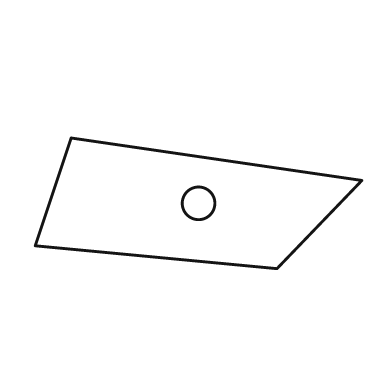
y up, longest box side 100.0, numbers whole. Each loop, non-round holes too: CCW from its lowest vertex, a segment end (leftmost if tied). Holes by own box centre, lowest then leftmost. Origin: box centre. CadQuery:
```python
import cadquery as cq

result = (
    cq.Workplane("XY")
    .moveTo(24.0, -20.0)
    .lineTo(50.0, 7.0)
    .lineTo(-39.0, 20.0)
    .lineTo(-50.0, -13.0)
    .close()
    .moveTo(0.0, 0.0)
    .circle(5.0)
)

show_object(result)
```